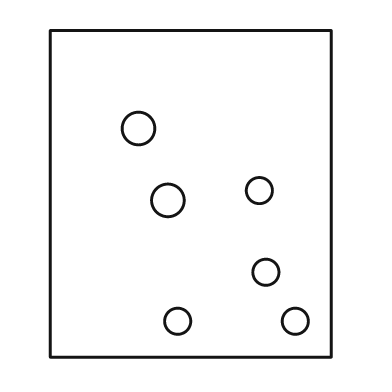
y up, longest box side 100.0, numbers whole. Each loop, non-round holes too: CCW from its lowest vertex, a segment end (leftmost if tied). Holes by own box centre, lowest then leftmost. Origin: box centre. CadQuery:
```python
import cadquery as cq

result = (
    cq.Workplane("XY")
    .moveTo(-43.0, -50.0)
    .lineTo(43.0, -50.0)
    .lineTo(43.0, 50.0)
    .lineTo(-43.0, 50.0)
    .close()
    .moveTo(-4.0, -39.0)
    .circle(4.0)
    .moveTo(32.0, -39.0)
    .circle(4.0)
    .moveTo(23.0, -24.0)
    .circle(4.0)
    .moveTo(-7.0, -2.0)
    .circle(5.0)
    .moveTo(21.0, 1.0)
    .circle(4.0)
    .moveTo(-16.0, 20.0)
    .circle(5.0)
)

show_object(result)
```